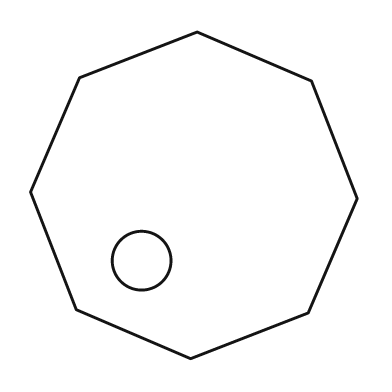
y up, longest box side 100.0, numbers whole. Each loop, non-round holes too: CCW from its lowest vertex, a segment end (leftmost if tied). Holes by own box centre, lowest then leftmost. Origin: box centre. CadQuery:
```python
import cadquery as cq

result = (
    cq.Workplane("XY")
    .moveTo(-1.0, -50.0)
    .lineTo(35.0, -36.0)
    .lineTo(50.0, -1.0)
    .lineTo(36.0, 35.0)
    .lineTo(1.0, 50.0)
    .lineTo(-35.0, 36.0)
    .lineTo(-50.0, 1.0)
    .lineTo(-36.0, -35.0)
    .close()
    .moveTo(-16.0, -20.0)
    .circle(9.0)
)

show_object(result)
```